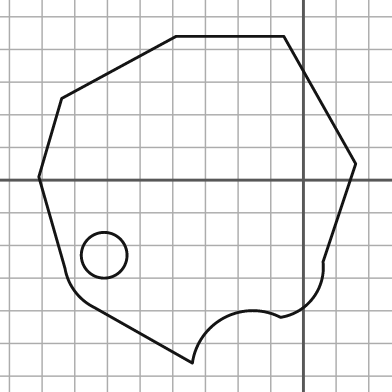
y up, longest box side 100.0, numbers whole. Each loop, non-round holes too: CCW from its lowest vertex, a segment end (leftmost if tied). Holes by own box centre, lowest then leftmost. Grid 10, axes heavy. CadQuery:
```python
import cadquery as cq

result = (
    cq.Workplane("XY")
    .moveTo(-34.0, -56.0)
    .threePointArc((-24.0, -42.0), (-7.0, -42.0))
    .threePointArc((3.0, -36.0), (6.0, -25.0))
    .lineTo(16.0, 5.0)
    .lineTo(-6.0, 44.0)
    .lineTo(-39.0, 44.0)
    .lineTo(-74.0, 25.0)
    .lineTo(-81.0, 1.0)
    .lineTo(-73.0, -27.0)
    .threePointArc((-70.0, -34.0), (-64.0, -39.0))
    .close()
    .moveTo(-61.0, -23.0)
    .circle(7.0)
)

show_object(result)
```